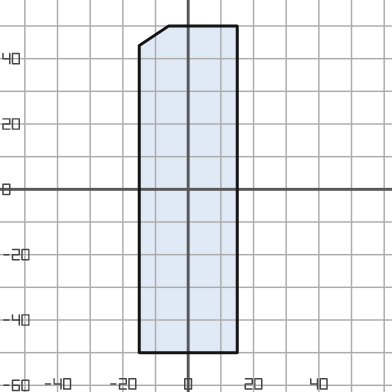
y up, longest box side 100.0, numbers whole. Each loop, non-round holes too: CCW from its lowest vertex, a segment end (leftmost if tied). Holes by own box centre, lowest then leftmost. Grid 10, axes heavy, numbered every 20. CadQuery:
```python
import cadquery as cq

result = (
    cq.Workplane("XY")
    .moveTo(-15.0, -50.0)
    .lineTo(15.0, -50.0)
    .lineTo(15.0, 50.0)
    .lineTo(-6.0, 50.0)
    .lineTo(-15.0, 44.0)
    .close()
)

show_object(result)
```